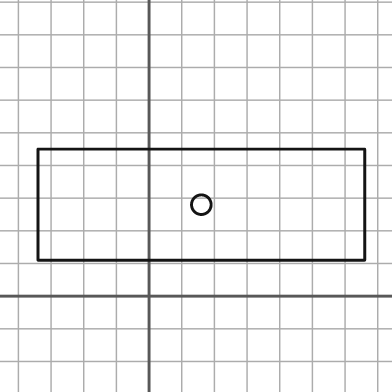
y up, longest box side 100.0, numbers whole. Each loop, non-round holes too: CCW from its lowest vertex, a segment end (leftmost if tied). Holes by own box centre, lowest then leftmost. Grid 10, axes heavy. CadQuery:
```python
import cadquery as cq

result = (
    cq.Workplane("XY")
    .moveTo(-34.0, 11.0)
    .lineTo(66.0, 11.0)
    .lineTo(66.0, 45.0)
    .lineTo(-34.0, 45.0)
    .close()
    .moveTo(16.0, 28.0)
    .circle(3.0)
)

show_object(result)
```